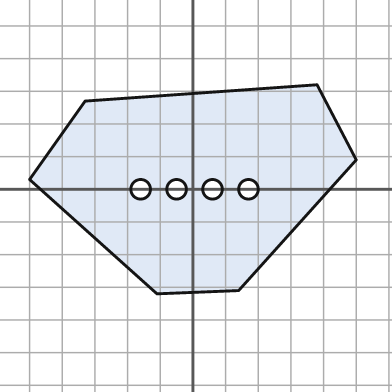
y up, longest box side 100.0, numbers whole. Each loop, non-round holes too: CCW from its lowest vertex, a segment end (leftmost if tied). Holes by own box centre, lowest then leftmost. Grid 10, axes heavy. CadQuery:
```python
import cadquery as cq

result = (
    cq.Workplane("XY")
    .moveTo(-11.0, -32.0)
    .lineTo(14.0, -31.0)
    .lineTo(50.0, 9.0)
    .lineTo(38.0, 32.0)
    .lineTo(-33.0, 27.0)
    .lineTo(-50.0, 3.0)
    .close()
    .moveTo(-16.0, 0.0)
    .circle(3.0)
    .moveTo(-5.0, 0.0)
    .circle(3.0)
    .moveTo(6.0, 0.0)
    .circle(3.0)
    .moveTo(17.0, 0.0)
    .circle(3.0)
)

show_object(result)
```